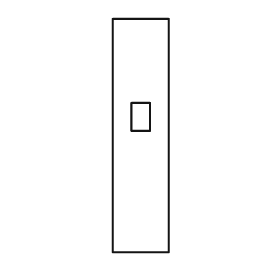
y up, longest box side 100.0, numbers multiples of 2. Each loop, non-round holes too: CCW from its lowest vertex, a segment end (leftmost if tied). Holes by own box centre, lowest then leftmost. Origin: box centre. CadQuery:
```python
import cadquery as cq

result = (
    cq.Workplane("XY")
    .moveTo(-12.0, -50.0)
    .lineTo(12.0, -50.0)
    .lineTo(12.0, 50.0)
    .lineTo(-12.0, 50.0)
    .close()
    .moveTo(-4.0, 2.0)
    .lineTo(4.0, 2.0)
    .lineTo(4.0, 14.0)
    .lineTo(-4.0, 14.0)
    .close()
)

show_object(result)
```